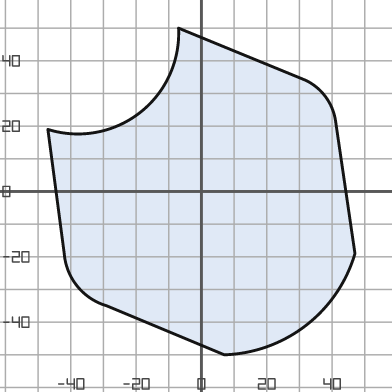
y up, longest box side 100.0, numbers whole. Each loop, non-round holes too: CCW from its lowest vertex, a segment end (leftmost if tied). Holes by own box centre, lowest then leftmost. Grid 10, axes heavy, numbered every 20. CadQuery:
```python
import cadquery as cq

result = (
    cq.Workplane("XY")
    .moveTo(7.0, -50.0)
    .threePointArc((32.0, -41.0), (47.0, -19.0))
    .lineTo(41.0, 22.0)
    .threePointArc((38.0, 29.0), (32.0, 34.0))
    .lineTo(-7.0, 50.0)
    .threePointArc((-19.0, 24.0), (-47.0, 19.0))
    .lineTo(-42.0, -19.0)
    .threePointArc((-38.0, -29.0), (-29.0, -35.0))
    .close()
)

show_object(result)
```